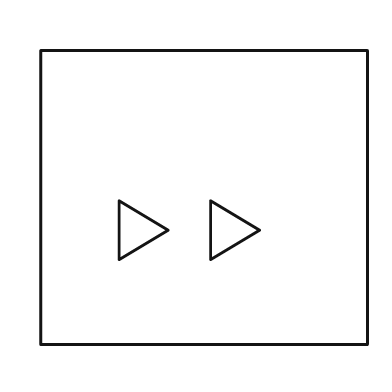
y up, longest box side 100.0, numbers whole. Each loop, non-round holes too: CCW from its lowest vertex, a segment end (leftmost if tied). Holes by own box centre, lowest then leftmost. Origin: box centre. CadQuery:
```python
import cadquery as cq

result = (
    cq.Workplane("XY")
    .moveTo(-50.0, -45.0)
    .lineTo(50.0, -45.0)
    .lineTo(50.0, 45.0)
    .lineTo(-50.0, 45.0)
    .close()
    .moveTo(-26.0, -19.0)
    .lineTo(-11.0, -10.0)
    .lineTo(-26.0, -1.0)
    .close()
    .moveTo(2.0, -19.0)
    .lineTo(17.0, -10.0)
    .lineTo(2.0, -1.0)
    .close()
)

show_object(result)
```